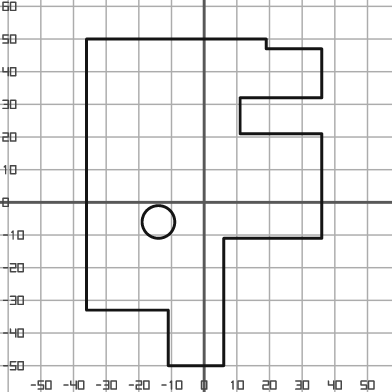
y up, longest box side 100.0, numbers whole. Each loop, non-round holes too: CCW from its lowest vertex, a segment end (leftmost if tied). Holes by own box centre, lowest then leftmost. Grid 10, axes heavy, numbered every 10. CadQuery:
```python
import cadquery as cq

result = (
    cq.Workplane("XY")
    .moveTo(-11.0, -50.0)
    .lineTo(6.0, -50.0)
    .lineTo(6.0, -11.0)
    .lineTo(36.0, -11.0)
    .lineTo(36.0, 21.0)
    .lineTo(11.0, 21.0)
    .lineTo(11.0, 32.0)
    .lineTo(36.0, 32.0)
    .lineTo(36.0, 47.0)
    .lineTo(19.0, 47.0)
    .lineTo(19.0, 50.0)
    .lineTo(-36.0, 50.0)
    .lineTo(-36.0, -33.0)
    .lineTo(-11.0, -33.0)
    .close()
    .moveTo(-14.0, -6.0)
    .circle(5.0)
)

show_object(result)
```